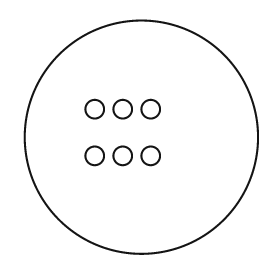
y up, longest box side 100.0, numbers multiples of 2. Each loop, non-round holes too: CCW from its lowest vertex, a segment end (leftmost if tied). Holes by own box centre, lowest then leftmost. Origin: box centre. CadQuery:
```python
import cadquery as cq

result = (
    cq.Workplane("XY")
    .moveTo(0.0, 0.0)
    .circle(50.0)
    .moveTo(-20.0, -8.0)
    .circle(4.0)
    .moveTo(-8.0, -8.0)
    .circle(4.0)
    .moveTo(4.0, -8.0)
    .circle(4.0)
    .moveTo(-20.0, 12.0)
    .circle(4.0)
    .moveTo(-8.0, 12.0)
    .circle(4.0)
    .moveTo(4.0, 12.0)
    .circle(4.0)
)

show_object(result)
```